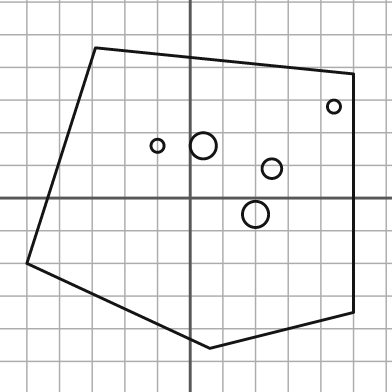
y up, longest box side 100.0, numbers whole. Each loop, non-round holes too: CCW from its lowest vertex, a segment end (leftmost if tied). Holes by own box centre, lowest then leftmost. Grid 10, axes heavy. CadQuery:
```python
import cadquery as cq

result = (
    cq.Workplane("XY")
    .moveTo(6.0, -46.0)
    .lineTo(50.0, -35.0)
    .lineTo(50.0, 38.0)
    .lineTo(-29.0, 46.0)
    .lineTo(-50.0, -20.0)
    .close()
    .moveTo(20.0, -5.0)
    .circle(4.0)
    .moveTo(25.0, 9.0)
    .circle(3.0)
    .moveTo(-10.0, 16.0)
    .circle(2.0)
    .moveTo(4.0, 16.0)
    .circle(4.0)
    .moveTo(44.0, 28.0)
    .circle(2.0)
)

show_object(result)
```